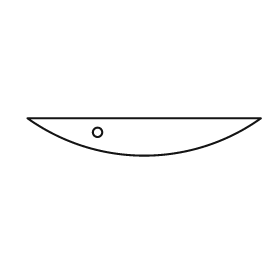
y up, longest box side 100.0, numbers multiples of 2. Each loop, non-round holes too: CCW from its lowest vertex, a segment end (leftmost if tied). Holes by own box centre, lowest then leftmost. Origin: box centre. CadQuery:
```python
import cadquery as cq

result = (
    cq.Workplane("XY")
    .moveTo(-50.0, 8.0)
    .threePointArc((0.0, -8.0), (50.0, 8.0))
    .close()
    .moveTo(-20.0, 2.0)
    .circle(2.0)
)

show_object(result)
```